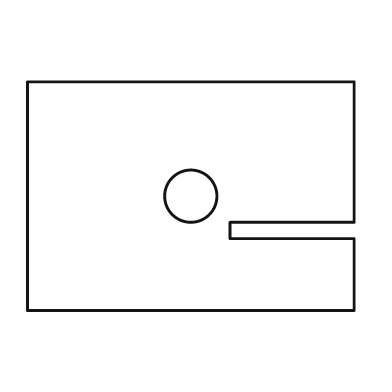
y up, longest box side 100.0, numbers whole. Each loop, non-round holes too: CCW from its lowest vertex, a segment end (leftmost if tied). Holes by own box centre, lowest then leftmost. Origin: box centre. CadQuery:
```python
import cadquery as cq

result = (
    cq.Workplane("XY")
    .moveTo(-50.0, -35.0)
    .lineTo(50.0, -35.0)
    .lineTo(50.0, -13.0)
    .lineTo(12.0, -13.0)
    .lineTo(12.0, -8.0)
    .lineTo(50.0, -8.0)
    .lineTo(50.0, 35.0)
    .lineTo(-50.0, 35.0)
    .close()
    .moveTo(0.0, 0.0)
    .circle(8.0)
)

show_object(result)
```